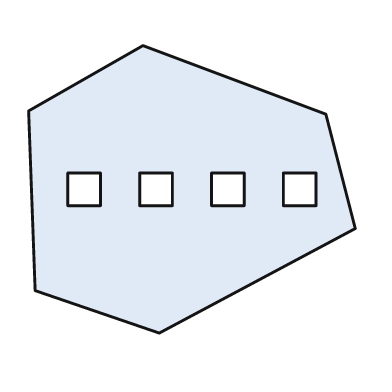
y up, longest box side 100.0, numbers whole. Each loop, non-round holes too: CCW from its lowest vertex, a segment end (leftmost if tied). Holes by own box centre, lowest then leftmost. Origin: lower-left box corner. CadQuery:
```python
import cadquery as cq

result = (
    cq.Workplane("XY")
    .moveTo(40.0, 0.0)
    .lineTo(100.0, 32.0)
    .lineTo(91.0, 67.0)
    .lineTo(35.0, 88.0)
    .lineTo(0.0, 68.0)
    .lineTo(2.0, 13.0)
    .close()
    .moveTo(12.0, 39.0)
    .lineTo(22.0, 39.0)
    .lineTo(22.0, 49.0)
    .lineTo(12.0, 49.0)
    .close()
    .moveTo(34.0, 39.0)
    .lineTo(44.0, 39.0)
    .lineTo(44.0, 49.0)
    .lineTo(34.0, 49.0)
    .close()
    .moveTo(56.0, 39.0)
    .lineTo(66.0, 39.0)
    .lineTo(66.0, 49.0)
    .lineTo(56.0, 49.0)
    .close()
    .moveTo(78.0, 39.0)
    .lineTo(88.0, 39.0)
    .lineTo(88.0, 49.0)
    .lineTo(78.0, 49.0)
    .close()
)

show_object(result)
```